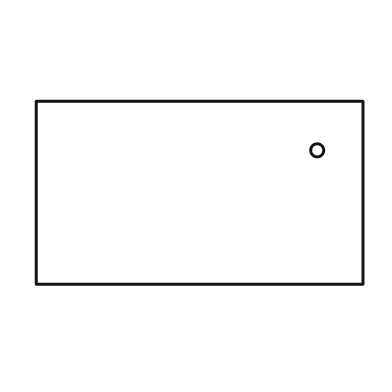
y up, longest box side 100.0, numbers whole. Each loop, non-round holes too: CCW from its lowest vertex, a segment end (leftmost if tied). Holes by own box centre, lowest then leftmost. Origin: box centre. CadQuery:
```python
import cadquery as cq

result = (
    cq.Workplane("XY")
    .moveTo(-50.0, -28.0)
    .lineTo(50.0, -28.0)
    .lineTo(50.0, 28.0)
    .lineTo(-50.0, 28.0)
    .close()
    .moveTo(36.0, 13.0)
    .circle(2.0)
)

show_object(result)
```